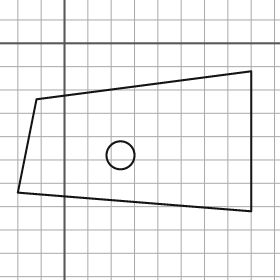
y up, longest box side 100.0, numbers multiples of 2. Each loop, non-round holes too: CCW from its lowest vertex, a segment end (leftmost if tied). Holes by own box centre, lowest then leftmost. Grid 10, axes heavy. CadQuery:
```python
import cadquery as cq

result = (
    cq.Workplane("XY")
    .moveTo(80.0, -72.0)
    .lineTo(80.0, -12.0)
    .lineTo(-12.0, -24.0)
    .lineTo(-20.0, -64.0)
    .close()
    .moveTo(24.0, -48.0)
    .circle(6.0)
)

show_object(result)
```